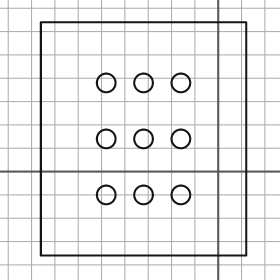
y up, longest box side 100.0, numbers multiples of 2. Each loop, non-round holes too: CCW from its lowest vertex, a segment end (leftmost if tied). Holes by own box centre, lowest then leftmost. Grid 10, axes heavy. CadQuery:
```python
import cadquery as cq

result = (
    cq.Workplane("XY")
    .moveTo(-76.0, -36.0)
    .lineTo(12.0, -36.0)
    .lineTo(12.0, 64.0)
    .lineTo(-76.0, 64.0)
    .close()
    .moveTo(-48.0, -10.0)
    .circle(4.0)
    .moveTo(-32.0, -10.0)
    .circle(4.0)
    .moveTo(-16.0, -10.0)
    .circle(4.0)
    .moveTo(-48.0, 14.0)
    .circle(4.0)
    .moveTo(-32.0, 14.0)
    .circle(4.0)
    .moveTo(-16.0, 14.0)
    .circle(4.0)
    .moveTo(-48.0, 38.0)
    .circle(4.0)
    .moveTo(-32.0, 38.0)
    .circle(4.0)
    .moveTo(-16.0, 38.0)
    .circle(4.0)
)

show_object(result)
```